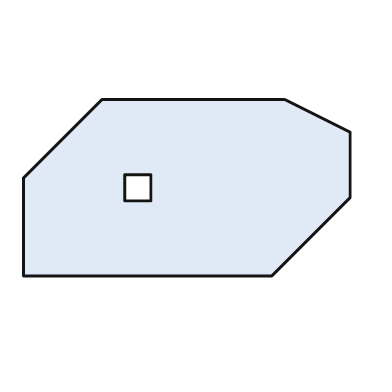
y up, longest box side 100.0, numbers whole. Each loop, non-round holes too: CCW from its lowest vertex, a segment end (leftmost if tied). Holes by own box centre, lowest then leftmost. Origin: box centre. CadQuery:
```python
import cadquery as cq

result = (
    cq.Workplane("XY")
    .moveTo(-50.0, -27.0)
    .lineTo(26.0, -27.0)
    .lineTo(50.0, -3.0)
    .lineTo(50.0, 17.0)
    .lineTo(30.0, 27.0)
    .lineTo(-26.0, 27.0)
    .lineTo(-50.0, 3.0)
    .close()
    .moveTo(-19.0, -4.0)
    .lineTo(-11.0, -4.0)
    .lineTo(-11.0, 4.0)
    .lineTo(-19.0, 4.0)
    .close()
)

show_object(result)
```